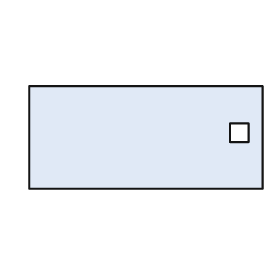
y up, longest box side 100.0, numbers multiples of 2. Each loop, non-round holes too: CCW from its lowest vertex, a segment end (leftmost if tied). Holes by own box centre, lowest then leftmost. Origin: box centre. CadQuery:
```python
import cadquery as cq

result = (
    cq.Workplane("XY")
    .moveTo(-50.0, -22.0)
    .lineTo(50.0, -22.0)
    .lineTo(50.0, 22.0)
    .lineTo(-50.0, 22.0)
    .close()
    .moveTo(36.0, -2.0)
    .lineTo(44.0, -2.0)
    .lineTo(44.0, 6.0)
    .lineTo(36.0, 6.0)
    .close()
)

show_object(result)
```